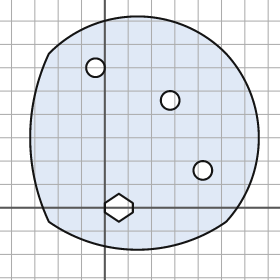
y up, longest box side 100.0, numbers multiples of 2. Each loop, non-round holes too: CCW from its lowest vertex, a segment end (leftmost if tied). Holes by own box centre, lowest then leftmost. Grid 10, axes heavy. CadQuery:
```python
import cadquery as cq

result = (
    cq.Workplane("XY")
    .moveTo(-24.0, -6.0)
    .threePointArc((14.0, -18.0), (52.0, -6.0))
    .threePointArc((66.0, 30.0), (52.0, 66.0))
    .threePointArc((14.0, 82.0), (-24.0, 66.0))
    .threePointArc((-32.0, 30.0), (-24.0, -6.0))
    .close()
    .moveTo(6.0, -6.0)
    .lineTo(12.0, -2.0)
    .lineTo(12.0, 2.0)
    .lineTo(6.0, 6.0)
    .lineTo(0.0, 2.0)
    .lineTo(0.0, -2.0)
    .close()
    .moveTo(42.0, 16.0)
    .circle(4.0)
    .moveTo(28.0, 46.0)
    .circle(4.0)
    .moveTo(-4.0, 60.0)
    .circle(4.0)
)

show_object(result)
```